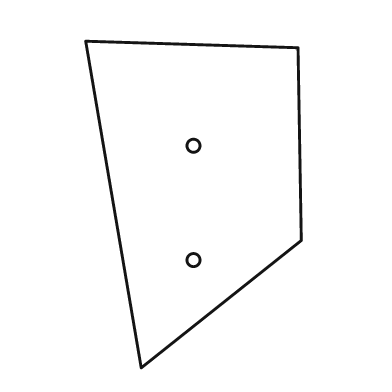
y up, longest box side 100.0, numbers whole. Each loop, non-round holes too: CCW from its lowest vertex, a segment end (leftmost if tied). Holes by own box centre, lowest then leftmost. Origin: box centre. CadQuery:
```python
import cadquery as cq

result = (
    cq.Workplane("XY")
    .moveTo(-16.0, -50.0)
    .lineTo(33.0, -11.0)
    .lineTo(32.0, 48.0)
    .lineTo(-33.0, 50.0)
    .close()
    .moveTo(0.0, -17.0)
    .circle(2.0)
    .moveTo(0.0, 18.0)
    .circle(2.0)
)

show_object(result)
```